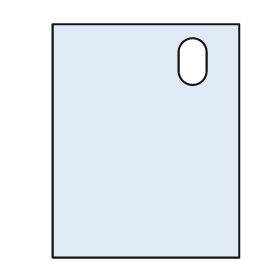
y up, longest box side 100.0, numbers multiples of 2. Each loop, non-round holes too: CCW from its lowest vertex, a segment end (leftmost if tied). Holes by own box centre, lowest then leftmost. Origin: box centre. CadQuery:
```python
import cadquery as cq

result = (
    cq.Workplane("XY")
    .moveTo(-40.0, -50.0)
    .lineTo(40.0, -50.0)
    .lineTo(40.0, 50.0)
    .lineTo(-40.0, 50.0)
    .close()
    .moveTo(14.0, 30.0)
    .threePointArc((20.0, 24.0), (26.0, 30.0))
    .lineTo(26.0, 38.0)
    .threePointArc((20.0, 44.0), (14.0, 38.0))
    .close()
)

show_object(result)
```